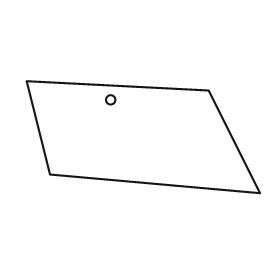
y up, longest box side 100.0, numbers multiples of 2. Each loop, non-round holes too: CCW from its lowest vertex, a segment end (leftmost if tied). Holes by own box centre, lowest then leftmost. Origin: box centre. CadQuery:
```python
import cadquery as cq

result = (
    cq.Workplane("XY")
    .moveTo(50.0, -24.0)
    .lineTo(28.0, 20.0)
    .lineTo(-50.0, 24.0)
    .lineTo(-40.0, -16.0)
    .close()
    .moveTo(-14.0, 16.0)
    .circle(2.0)
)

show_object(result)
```